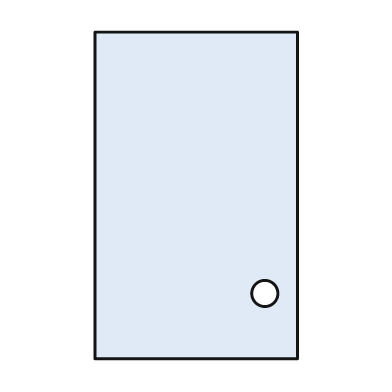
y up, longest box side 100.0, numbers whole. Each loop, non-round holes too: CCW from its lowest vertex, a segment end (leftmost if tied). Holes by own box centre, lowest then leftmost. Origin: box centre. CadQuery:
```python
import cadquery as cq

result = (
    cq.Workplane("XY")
    .moveTo(-31.0, -50.0)
    .lineTo(31.0, -50.0)
    .lineTo(31.0, 50.0)
    .lineTo(-31.0, 50.0)
    .close()
    .moveTo(21.0, -30.0)
    .circle(4.0)
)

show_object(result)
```